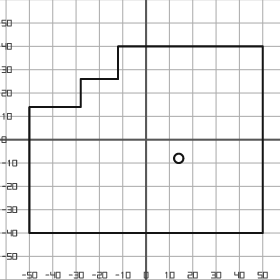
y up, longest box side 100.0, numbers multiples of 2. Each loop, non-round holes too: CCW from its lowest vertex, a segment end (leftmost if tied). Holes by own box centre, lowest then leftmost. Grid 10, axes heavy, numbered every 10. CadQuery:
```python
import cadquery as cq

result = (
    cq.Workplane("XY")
    .moveTo(-50.0, -40.0)
    .lineTo(50.0, -40.0)
    .lineTo(50.0, 40.0)
    .lineTo(-12.0, 40.0)
    .lineTo(-12.0, 26.0)
    .lineTo(-28.0, 26.0)
    .lineTo(-28.0, 14.0)
    .lineTo(-50.0, 14.0)
    .close()
    .moveTo(14.0, -8.0)
    .circle(2.0)
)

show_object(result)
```